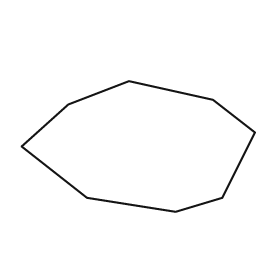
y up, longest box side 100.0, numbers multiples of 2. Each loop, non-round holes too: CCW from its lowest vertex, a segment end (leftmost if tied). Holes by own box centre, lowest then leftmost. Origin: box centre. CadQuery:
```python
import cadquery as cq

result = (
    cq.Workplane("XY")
    .moveTo(16.0, -28.0)
    .lineTo(36.0, -22.0)
    .lineTo(50.0, 6.0)
    .lineTo(32.0, 20.0)
    .lineTo(-4.0, 28.0)
    .lineTo(-30.0, 18.0)
    .lineTo(-50.0, 0.0)
    .lineTo(-22.0, -22.0)
    .close()
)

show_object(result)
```